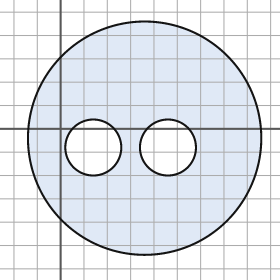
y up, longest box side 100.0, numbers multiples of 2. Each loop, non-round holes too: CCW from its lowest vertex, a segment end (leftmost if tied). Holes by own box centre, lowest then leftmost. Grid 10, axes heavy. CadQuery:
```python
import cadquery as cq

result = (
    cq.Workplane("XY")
    .moveTo(36.0, -4.0)
    .circle(50.0)
    .moveTo(14.0, -8.0)
    .circle(12.0)
    .moveTo(46.0, -8.0)
    .circle(12.0)
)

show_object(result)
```